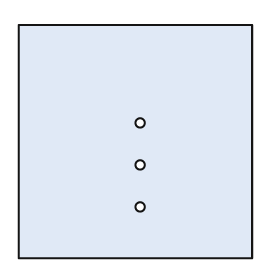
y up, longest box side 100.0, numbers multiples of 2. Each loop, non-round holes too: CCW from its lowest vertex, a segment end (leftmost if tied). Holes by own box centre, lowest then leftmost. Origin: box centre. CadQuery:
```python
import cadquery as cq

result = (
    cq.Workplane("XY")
    .moveTo(-50.0, -50.0)
    .lineTo(50.0, -50.0)
    .lineTo(50.0, 50.0)
    .lineTo(-50.0, 50.0)
    .close()
    .moveTo(2.0, -28.0)
    .circle(2.0)
    .moveTo(2.0, -10.0)
    .circle(2.0)
    .moveTo(2.0, 8.0)
    .circle(2.0)
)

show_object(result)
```